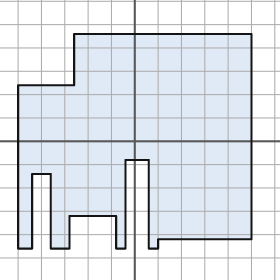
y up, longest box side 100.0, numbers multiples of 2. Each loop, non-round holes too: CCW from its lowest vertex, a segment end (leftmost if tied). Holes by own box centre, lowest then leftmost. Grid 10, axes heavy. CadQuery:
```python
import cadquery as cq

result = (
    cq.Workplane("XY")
    .moveTo(-50.0, -46.0)
    .lineTo(-44.0, -46.0)
    .lineTo(-44.0, -14.0)
    .lineTo(-36.0, -14.0)
    .lineTo(-36.0, -46.0)
    .lineTo(-28.0, -46.0)
    .lineTo(-28.0, -32.0)
    .lineTo(-8.0, -32.0)
    .lineTo(-8.0, -46.0)
    .lineTo(-4.0, -46.0)
    .lineTo(-4.0, -8.0)
    .lineTo(6.0, -8.0)
    .lineTo(6.0, -46.0)
    .lineTo(10.0, -46.0)
    .lineTo(10.0, -42.0)
    .lineTo(50.0, -42.0)
    .lineTo(50.0, 46.0)
    .lineTo(-26.0, 46.0)
    .lineTo(-26.0, 24.0)
    .lineTo(-50.0, 24.0)
    .close()
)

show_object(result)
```